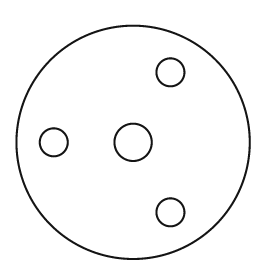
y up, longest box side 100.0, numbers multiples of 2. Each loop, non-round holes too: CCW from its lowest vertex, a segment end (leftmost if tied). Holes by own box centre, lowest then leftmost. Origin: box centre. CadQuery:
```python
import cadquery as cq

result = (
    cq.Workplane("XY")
    .moveTo(0.0, 0.0)
    .circle(50.0)
    .moveTo(16.0, -30.0)
    .circle(6.0)
    .moveTo(-34.0, 0.0)
    .circle(6.0)
    .moveTo(0.0, 0.0)
    .circle(8.0)
    .moveTo(16.0, 30.0)
    .circle(6.0)
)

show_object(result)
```